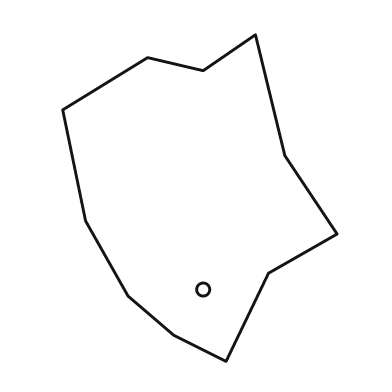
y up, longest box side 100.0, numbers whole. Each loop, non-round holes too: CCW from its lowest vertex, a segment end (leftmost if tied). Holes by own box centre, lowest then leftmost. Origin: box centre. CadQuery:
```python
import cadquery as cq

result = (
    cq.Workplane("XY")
    .moveTo(8.0, -50.0)
    .lineTo(21.0, -23.0)
    .lineTo(42.0, -11.0)
    .lineTo(26.0, 13.0)
    .lineTo(17.0, 50.0)
    .lineTo(1.0, 39.0)
    .lineTo(-16.0, 43.0)
    .lineTo(-42.0, 27.0)
    .lineTo(-35.0, -7.0)
    .lineTo(-22.0, -30.0)
    .lineTo(-8.0, -42.0)
    .close()
    .moveTo(1.0, -28.0)
    .circle(2.0)
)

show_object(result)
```